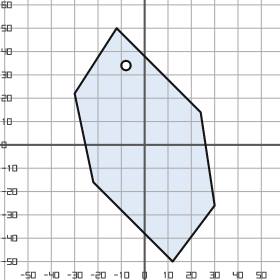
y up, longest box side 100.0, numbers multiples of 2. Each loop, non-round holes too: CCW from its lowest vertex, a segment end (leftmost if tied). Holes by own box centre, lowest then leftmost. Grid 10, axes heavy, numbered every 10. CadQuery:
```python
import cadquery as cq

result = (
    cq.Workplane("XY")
    .moveTo(12.0, -50.0)
    .lineTo(30.0, -26.0)
    .lineTo(24.0, 14.0)
    .lineTo(-12.0, 50.0)
    .lineTo(-30.0, 22.0)
    .lineTo(-22.0, -16.0)
    .close()
    .moveTo(-8.0, 34.0)
    .circle(2.0)
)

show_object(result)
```